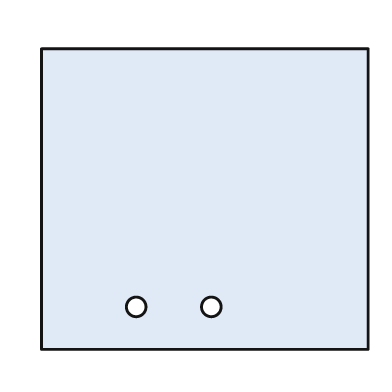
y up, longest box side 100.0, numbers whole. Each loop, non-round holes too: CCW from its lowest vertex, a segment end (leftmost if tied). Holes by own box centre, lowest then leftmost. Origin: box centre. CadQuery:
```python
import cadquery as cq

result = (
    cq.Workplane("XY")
    .moveTo(-50.0, -46.0)
    .lineTo(50.0, -46.0)
    .lineTo(50.0, 46.0)
    .lineTo(-50.0, 46.0)
    .close()
    .moveTo(-21.0, -33.0)
    .circle(3.0)
    .moveTo(2.0, -33.0)
    .circle(3.0)
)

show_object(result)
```